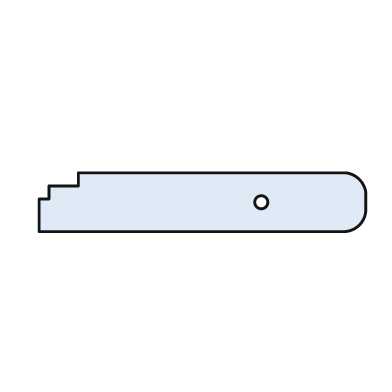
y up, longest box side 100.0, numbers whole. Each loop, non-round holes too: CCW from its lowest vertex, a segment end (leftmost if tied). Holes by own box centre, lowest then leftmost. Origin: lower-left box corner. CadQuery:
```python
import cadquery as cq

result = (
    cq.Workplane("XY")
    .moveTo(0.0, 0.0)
    .lineTo(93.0, 0.0)
    .threePointArc((98.0, 2.0), (100.0, 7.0))
    .lineTo(100.0, 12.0)
    .threePointArc((98.0, 16.0), (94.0, 18.0))
    .lineTo(12.0, 18.0)
    .lineTo(12.0, 14.0)
    .lineTo(3.0, 14.0)
    .lineTo(3.0, 10.0)
    .lineTo(0.0, 10.0)
    .close()
    .moveTo(68.0, 9.0)
    .circle(2.0)
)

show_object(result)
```